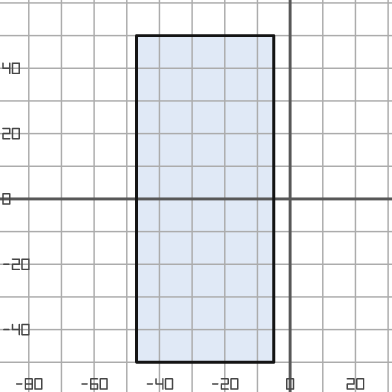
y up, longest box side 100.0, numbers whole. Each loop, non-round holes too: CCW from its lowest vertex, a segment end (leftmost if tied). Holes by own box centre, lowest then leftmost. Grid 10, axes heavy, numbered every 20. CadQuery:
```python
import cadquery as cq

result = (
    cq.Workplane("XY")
    .moveTo(-47.0, -50.0)
    .lineTo(-5.0, -50.0)
    .lineTo(-5.0, 50.0)
    .lineTo(-47.0, 50.0)
    .close()
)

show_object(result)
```